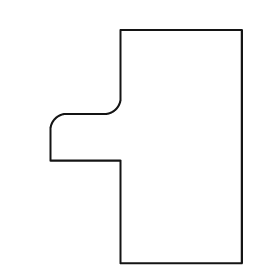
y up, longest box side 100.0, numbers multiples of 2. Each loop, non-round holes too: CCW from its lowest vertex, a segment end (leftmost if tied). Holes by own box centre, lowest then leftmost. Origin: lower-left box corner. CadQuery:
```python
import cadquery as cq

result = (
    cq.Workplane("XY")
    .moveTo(30.0, 0.0)
    .lineTo(82.0, 0.0)
    .lineTo(82.0, 100.0)
    .lineTo(30.0, 100.0)
    .lineTo(30.0, 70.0)
    .threePointArc((28.0, 66.0), (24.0, 64.0))
    .lineTo(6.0, 64.0)
    .threePointArc((2.0, 62.0), (0.0, 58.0))
    .lineTo(0.0, 44.0)
    .lineTo(30.0, 44.0)
    .close()
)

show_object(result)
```